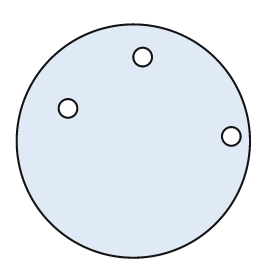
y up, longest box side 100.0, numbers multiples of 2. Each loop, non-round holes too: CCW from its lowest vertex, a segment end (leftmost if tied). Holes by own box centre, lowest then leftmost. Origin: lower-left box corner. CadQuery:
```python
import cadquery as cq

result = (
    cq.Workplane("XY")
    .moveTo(50.0, 50.0)
    .circle(50.0)
    .moveTo(92.0, 52.0)
    .circle(4.0)
    .moveTo(22.0, 64.0)
    .circle(4.0)
    .moveTo(54.0, 86.0)
    .circle(4.0)
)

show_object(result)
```